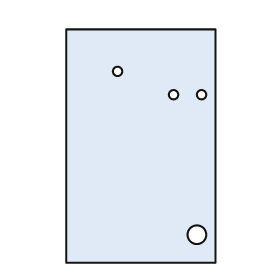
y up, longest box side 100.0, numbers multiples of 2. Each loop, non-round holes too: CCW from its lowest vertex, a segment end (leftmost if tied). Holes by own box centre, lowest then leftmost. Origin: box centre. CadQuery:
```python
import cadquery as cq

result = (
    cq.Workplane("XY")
    .moveTo(-32.0, -50.0)
    .lineTo(32.0, -50.0)
    .lineTo(32.0, 50.0)
    .lineTo(-32.0, 50.0)
    .close()
    .moveTo(24.0, -38.0)
    .circle(4.0)
    .moveTo(14.0, 22.0)
    .circle(2.0)
    .moveTo(26.0, 22.0)
    .circle(2.0)
    .moveTo(-10.0, 32.0)
    .circle(2.0)
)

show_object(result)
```